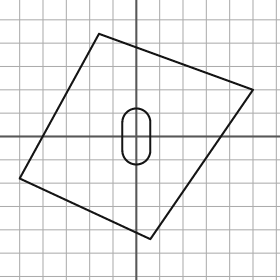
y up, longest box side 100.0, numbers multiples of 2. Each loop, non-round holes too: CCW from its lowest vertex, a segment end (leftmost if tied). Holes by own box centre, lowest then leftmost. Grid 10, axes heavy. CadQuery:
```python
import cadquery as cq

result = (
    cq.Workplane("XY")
    .moveTo(6.0, -44.0)
    .lineTo(50.0, 20.0)
    .lineTo(-16.0, 44.0)
    .lineTo(-50.0, -18.0)
    .close()
    .moveTo(-6.0, -6.0)
    .threePointArc((0.0, -12.0), (6.0, -6.0))
    .lineTo(6.0, 6.0)
    .threePointArc((0.0, 12.0), (-6.0, 6.0))
    .close()
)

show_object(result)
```